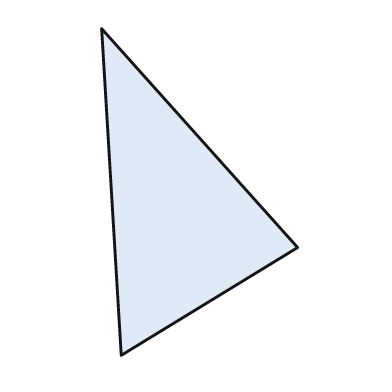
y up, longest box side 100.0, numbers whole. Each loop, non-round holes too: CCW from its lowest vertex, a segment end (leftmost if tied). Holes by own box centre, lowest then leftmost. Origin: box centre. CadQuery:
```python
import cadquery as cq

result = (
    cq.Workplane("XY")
    .moveTo(-24.0, -50.0)
    .lineTo(30.0, -17.0)
    .lineTo(-30.0, 50.0)
    .close()
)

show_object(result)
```